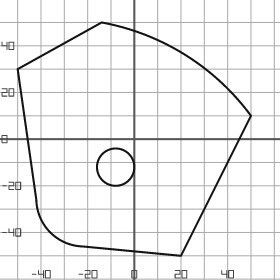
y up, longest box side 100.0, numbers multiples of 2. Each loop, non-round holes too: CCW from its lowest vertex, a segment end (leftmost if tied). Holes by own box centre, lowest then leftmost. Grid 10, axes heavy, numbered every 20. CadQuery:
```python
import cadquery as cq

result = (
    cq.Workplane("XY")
    .moveTo(20.0, -50.0)
    .lineTo(50.0, 10.0)
    .threePointArc((22.0, 36.0), (-14.0, 50.0))
    .lineTo(-50.0, 30.0)
    .lineTo(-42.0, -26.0)
    .threePointArc((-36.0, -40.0), (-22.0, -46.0))
    .close()
    .moveTo(-8.0, -12.0)
    .circle(8.0)
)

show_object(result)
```